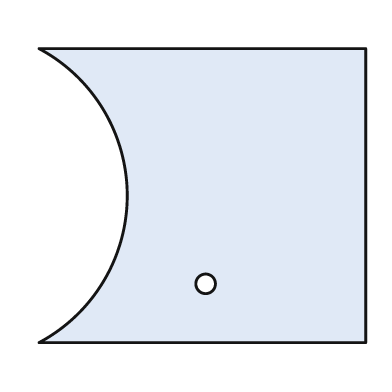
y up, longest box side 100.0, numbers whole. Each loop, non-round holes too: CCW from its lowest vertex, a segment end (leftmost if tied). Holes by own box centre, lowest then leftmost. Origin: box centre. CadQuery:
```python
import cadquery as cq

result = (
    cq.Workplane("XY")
    .moveTo(-50.0, -45.0)
    .lineTo(50.0, -45.0)
    .lineTo(50.0, 45.0)
    .lineTo(-50.0, 45.0)
    .threePointArc((-23.0, 0.0), (-50.0, -45.0))
    .close()
    .moveTo(1.0, -27.0)
    .circle(3.0)
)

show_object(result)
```